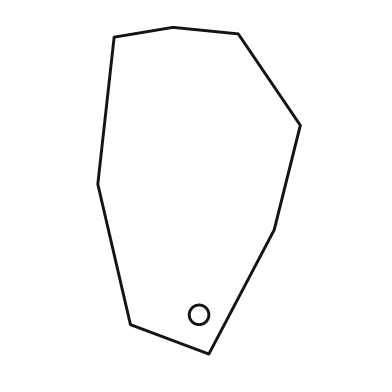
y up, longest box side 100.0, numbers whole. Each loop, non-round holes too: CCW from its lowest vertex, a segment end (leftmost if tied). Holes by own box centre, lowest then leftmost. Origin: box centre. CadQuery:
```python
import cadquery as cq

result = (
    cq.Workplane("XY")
    .moveTo(3.0, -50.0)
    .lineTo(23.0, -12.0)
    .lineTo(31.0, 20.0)
    .lineTo(12.0, 48.0)
    .lineTo(-8.0, 50.0)
    .lineTo(-26.0, 47.0)
    .lineTo(-31.0, 2.0)
    .lineTo(-21.0, -41.0)
    .close()
    .moveTo(0.0, -38.0)
    .circle(3.0)
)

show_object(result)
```